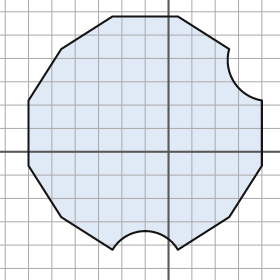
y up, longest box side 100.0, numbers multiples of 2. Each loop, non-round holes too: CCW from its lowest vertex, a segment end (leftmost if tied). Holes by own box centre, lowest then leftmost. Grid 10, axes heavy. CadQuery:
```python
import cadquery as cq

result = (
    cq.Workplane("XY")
    .moveTo(-24.0, -42.0)
    .threePointArc((-10.0, -34.0), (4.0, -42.0))
    .lineTo(26.0, -28.0)
    .lineTo(40.0, -6.0)
    .lineTo(40.0, 22.0)
    .threePointArc((28.0, 30.0), (26.0, 44.0))
    .lineTo(4.0, 58.0)
    .lineTo(-24.0, 58.0)
    .lineTo(-46.0, 44.0)
    .lineTo(-60.0, 22.0)
    .lineTo(-60.0, -6.0)
    .lineTo(-46.0, -28.0)
    .close()
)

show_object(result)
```